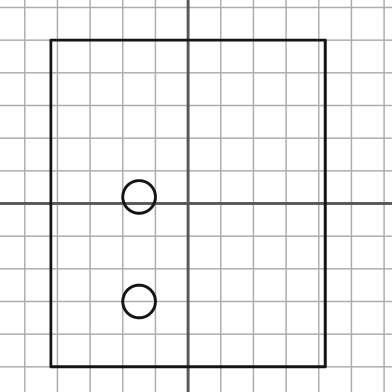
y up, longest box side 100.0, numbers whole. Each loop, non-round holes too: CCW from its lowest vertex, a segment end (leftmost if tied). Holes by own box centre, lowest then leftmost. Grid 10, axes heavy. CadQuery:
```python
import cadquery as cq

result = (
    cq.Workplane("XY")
    .moveTo(-42.0, -50.0)
    .lineTo(42.0, -50.0)
    .lineTo(42.0, 50.0)
    .lineTo(-42.0, 50.0)
    .close()
    .moveTo(-15.0, -30.0)
    .circle(5.0)
    .moveTo(-15.0, 2.0)
    .circle(5.0)
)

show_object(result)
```